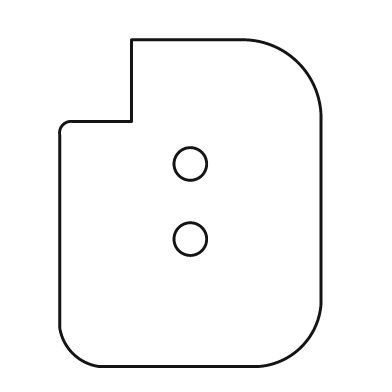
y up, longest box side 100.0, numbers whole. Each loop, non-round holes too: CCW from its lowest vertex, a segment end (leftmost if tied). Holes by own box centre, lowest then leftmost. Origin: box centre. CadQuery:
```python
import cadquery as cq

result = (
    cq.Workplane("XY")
    .moveTo(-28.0, -50.0)
    .lineTo(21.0, -50.0)
    .threePointArc((34.0, -44.0), (40.0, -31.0))
    .lineTo(40.0, 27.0)
    .threePointArc((33.0, 43.0), (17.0, 50.0))
    .lineTo(-18.0, 50.0)
    .lineTo(-18.0, 25.0)
    .lineTo(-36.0, 25.0)
    .threePointArc((-39.0, 24.0), (-40.0, 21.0))
    .lineTo(-40.0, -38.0)
    .threePointArc((-36.0, -46.0), (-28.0, -50.0))
    .close()
    .moveTo(0.0, -11.0)
    .circle(5.0)
    .moveTo(0.0, 12.0)
    .circle(5.0)
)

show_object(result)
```